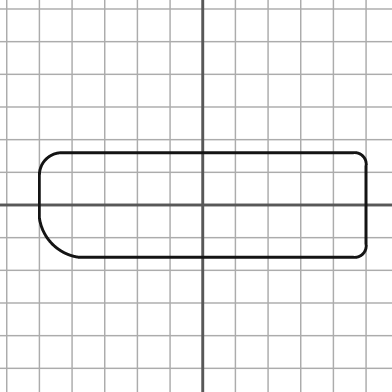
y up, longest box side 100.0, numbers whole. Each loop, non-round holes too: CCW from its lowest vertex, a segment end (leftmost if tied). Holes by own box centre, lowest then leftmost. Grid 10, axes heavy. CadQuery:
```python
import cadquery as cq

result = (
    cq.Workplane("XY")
    .moveTo(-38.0, -16.0)
    .lineTo(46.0, -16.0)
    .threePointArc((49.0, -15.0), (50.0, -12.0))
    .lineTo(50.0, 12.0)
    .threePointArc((49.0, 15.0), (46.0, 16.0))
    .lineTo(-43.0, 16.0)
    .threePointArc((-48.0, 14.0), (-50.0, 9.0))
    .lineTo(-50.0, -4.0)
    .threePointArc((-46.0, -12.0), (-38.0, -16.0))
    .close()
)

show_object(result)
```